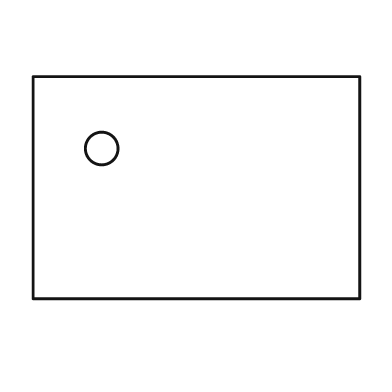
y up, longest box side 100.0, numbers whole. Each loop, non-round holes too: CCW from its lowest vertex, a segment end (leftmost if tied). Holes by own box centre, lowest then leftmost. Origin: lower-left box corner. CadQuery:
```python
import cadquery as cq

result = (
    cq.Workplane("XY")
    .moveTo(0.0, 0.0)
    .lineTo(100.0, 0.0)
    .lineTo(100.0, 68.0)
    .lineTo(0.0, 68.0)
    .close()
    .moveTo(21.0, 46.0)
    .circle(5.0)
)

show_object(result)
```